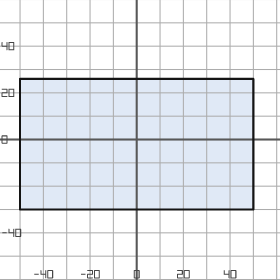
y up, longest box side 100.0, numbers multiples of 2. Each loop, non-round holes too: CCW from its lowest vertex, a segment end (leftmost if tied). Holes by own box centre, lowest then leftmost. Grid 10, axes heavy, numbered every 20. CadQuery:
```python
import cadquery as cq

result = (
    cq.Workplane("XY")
    .moveTo(-50.0, -30.0)
    .lineTo(50.0, -30.0)
    .lineTo(50.0, 26.0)
    .lineTo(-50.0, 26.0)
    .close()
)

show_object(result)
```